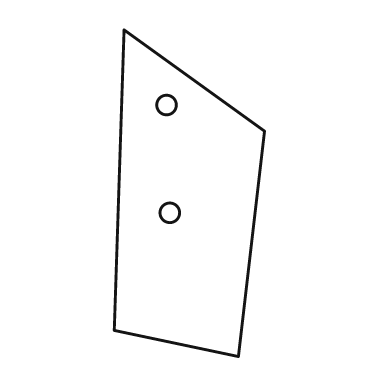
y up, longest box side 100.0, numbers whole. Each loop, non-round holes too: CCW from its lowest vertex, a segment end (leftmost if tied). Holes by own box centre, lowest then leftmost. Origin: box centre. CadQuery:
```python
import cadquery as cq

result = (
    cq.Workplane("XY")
    .moveTo(15.0, -50.0)
    .lineTo(23.0, 19.0)
    .lineTo(-20.0, 50.0)
    .lineTo(-23.0, -42.0)
    .close()
    .moveTo(-6.0, -6.0)
    .circle(3.0)
    .moveTo(-7.0, 27.0)
    .circle(3.0)
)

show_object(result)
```